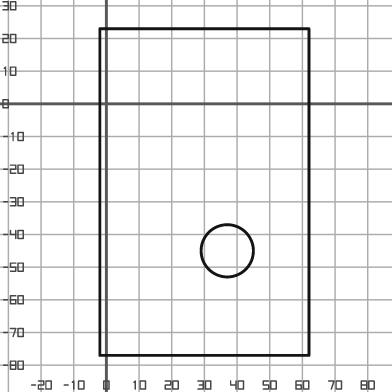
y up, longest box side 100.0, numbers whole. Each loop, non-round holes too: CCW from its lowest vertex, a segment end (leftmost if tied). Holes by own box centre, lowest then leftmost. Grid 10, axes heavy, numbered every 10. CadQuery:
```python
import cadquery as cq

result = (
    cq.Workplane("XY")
    .moveTo(-2.0, -77.0)
    .lineTo(62.0, -77.0)
    .lineTo(62.0, 23.0)
    .lineTo(-2.0, 23.0)
    .close()
    .moveTo(37.0, -45.0)
    .circle(8.0)
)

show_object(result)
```